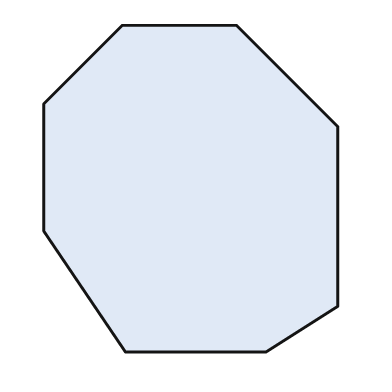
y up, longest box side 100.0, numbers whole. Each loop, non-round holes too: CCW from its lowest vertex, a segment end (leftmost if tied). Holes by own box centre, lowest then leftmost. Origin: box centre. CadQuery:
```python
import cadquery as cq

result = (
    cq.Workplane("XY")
    .moveTo(-20.0, -50.0)
    .lineTo(23.0, -50.0)
    .lineTo(45.0, -36.0)
    .lineTo(45.0, 19.0)
    .lineTo(14.0, 50.0)
    .lineTo(-21.0, 50.0)
    .lineTo(-45.0, 26.0)
    .lineTo(-45.0, -13.0)
    .close()
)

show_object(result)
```